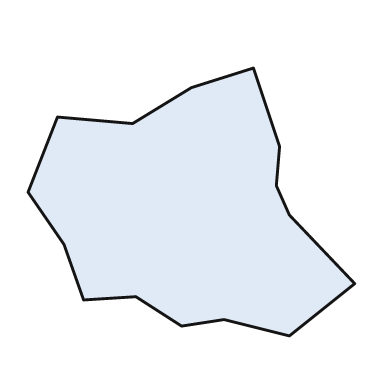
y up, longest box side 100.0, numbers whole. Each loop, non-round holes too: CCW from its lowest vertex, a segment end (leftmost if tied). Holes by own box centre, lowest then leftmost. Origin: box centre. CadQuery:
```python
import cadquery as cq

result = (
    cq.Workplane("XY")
    .moveTo(30.0, -41.0)
    .lineTo(50.0, -25.0)
    .lineTo(30.0, -4.0)
    .lineTo(26.0, 5.0)
    .lineTo(27.0, 17.0)
    .lineTo(19.0, 41.0)
    .lineTo(0.0, 35.0)
    .lineTo(-18.0, 24.0)
    .lineTo(-41.0, 26.0)
    .lineTo(-50.0, 3.0)
    .lineTo(-39.0, -13.0)
    .lineTo(-33.0, -30.0)
    .lineTo(-17.0, -29.0)
    .lineTo(-3.0, -38.0)
    .lineTo(10.0, -36.0)
    .close()
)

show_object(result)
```